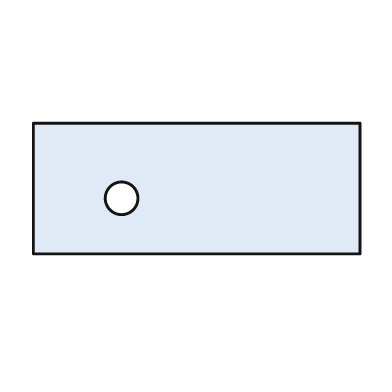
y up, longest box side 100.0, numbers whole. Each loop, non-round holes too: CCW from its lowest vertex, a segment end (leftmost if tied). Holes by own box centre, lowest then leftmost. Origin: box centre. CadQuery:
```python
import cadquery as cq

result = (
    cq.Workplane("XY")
    .moveTo(-50.0, -20.0)
    .lineTo(50.0, -20.0)
    .lineTo(50.0, 20.0)
    .lineTo(-50.0, 20.0)
    .close()
    .moveTo(-23.0, -3.0)
    .circle(5.0)
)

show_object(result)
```